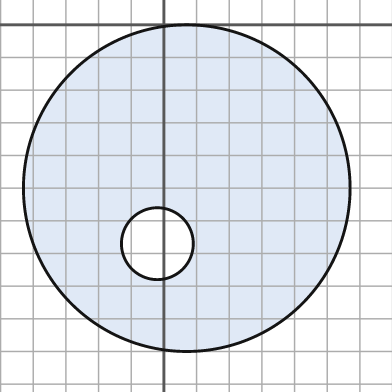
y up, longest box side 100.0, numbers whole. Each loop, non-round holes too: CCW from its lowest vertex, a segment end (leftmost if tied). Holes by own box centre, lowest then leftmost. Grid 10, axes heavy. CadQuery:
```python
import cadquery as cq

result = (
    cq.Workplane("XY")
    .moveTo(7.0, -50.0)
    .circle(50.0)
    .moveTo(-2.0, -67.0)
    .circle(11.0)
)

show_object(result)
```